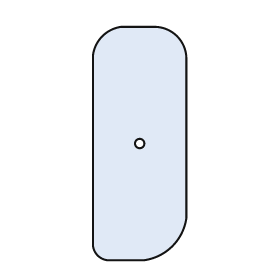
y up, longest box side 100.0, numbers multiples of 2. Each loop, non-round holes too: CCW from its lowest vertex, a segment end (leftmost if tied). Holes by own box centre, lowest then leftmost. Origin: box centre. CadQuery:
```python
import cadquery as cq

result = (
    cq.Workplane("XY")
    .moveTo(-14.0, -50.0)
    .lineTo(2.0, -50.0)
    .threePointArc((14.0, -44.0), (20.0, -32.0))
    .lineTo(20.0, 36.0)
    .threePointArc((16.0, 46.0), (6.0, 50.0))
    .lineTo(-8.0, 50.0)
    .threePointArc((-16.0, 46.0), (-20.0, 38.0))
    .lineTo(-20.0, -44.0)
    .threePointArc((-18.0, -48.0), (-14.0, -50.0))
    .close()
    .moveTo(0.0, 0.0)
    .circle(2.0)
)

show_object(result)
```